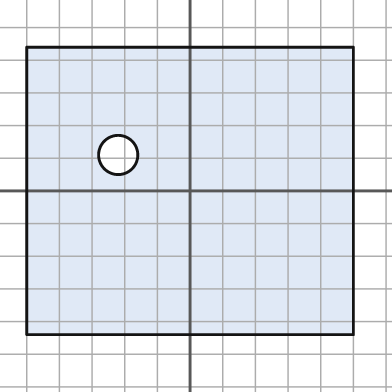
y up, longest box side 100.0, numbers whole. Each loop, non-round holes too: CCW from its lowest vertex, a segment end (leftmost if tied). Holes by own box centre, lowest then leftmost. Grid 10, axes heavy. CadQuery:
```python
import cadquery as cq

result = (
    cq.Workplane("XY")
    .moveTo(-50.0, -44.0)
    .lineTo(50.0, -44.0)
    .lineTo(50.0, 44.0)
    .lineTo(-50.0, 44.0)
    .close()
    .moveTo(-22.0, 11.0)
    .circle(6.0)
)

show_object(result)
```